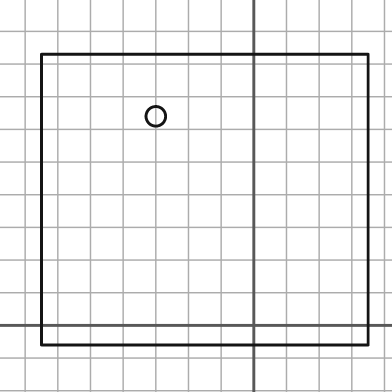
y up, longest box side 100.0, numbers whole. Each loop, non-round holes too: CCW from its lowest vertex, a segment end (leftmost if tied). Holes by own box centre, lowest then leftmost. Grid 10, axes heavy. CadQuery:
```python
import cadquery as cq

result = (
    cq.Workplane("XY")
    .moveTo(-65.0, -6.0)
    .lineTo(35.0, -6.0)
    .lineTo(35.0, 83.0)
    .lineTo(-65.0, 83.0)
    .close()
    .moveTo(-30.0, 64.0)
    .circle(3.0)
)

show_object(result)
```